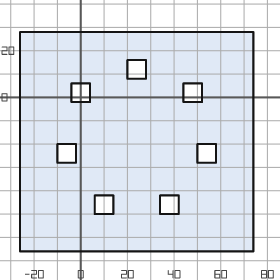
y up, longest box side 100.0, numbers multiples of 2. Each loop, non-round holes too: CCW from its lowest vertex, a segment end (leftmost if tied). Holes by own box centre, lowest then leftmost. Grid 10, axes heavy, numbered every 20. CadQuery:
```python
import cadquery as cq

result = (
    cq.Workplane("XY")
    .moveTo(-26.0, -66.0)
    .lineTo(74.0, -66.0)
    .lineTo(74.0, 28.0)
    .lineTo(-26.0, 28.0)
    .close()
    .moveTo(6.0, -50.0)
    .lineTo(14.0, -50.0)
    .lineTo(14.0, -42.0)
    .lineTo(6.0, -42.0)
    .close()
    .moveTo(34.0, -50.0)
    .lineTo(42.0, -50.0)
    .lineTo(42.0, -42.0)
    .lineTo(34.0, -42.0)
    .close()
    .moveTo(-10.0, -28.0)
    .lineTo(-2.0, -28.0)
    .lineTo(-2.0, -20.0)
    .lineTo(-10.0, -20.0)
    .close()
    .moveTo(50.0, -28.0)
    .lineTo(58.0, -28.0)
    .lineTo(58.0, -20.0)
    .lineTo(50.0, -20.0)
    .close()
    .moveTo(-4.0, -2.0)
    .lineTo(4.0, -2.0)
    .lineTo(4.0, 6.0)
    .lineTo(-4.0, 6.0)
    .close()
    .moveTo(44.0, -2.0)
    .lineTo(52.0, -2.0)
    .lineTo(52.0, 6.0)
    .lineTo(44.0, 6.0)
    .close()
    .moveTo(20.0, 8.0)
    .lineTo(28.0, 8.0)
    .lineTo(28.0, 16.0)
    .lineTo(20.0, 16.0)
    .close()
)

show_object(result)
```